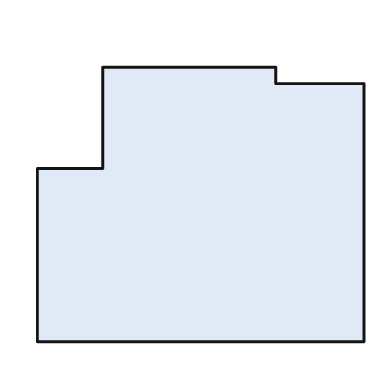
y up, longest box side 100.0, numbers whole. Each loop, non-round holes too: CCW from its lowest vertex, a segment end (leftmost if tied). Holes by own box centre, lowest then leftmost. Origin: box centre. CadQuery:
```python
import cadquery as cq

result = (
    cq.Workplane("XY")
    .moveTo(-50.0, -42.0)
    .lineTo(50.0, -42.0)
    .lineTo(50.0, 37.0)
    .lineTo(23.0, 37.0)
    .lineTo(23.0, 42.0)
    .lineTo(-30.0, 42.0)
    .lineTo(-30.0, 11.0)
    .lineTo(-50.0, 11.0)
    .close()
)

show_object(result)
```